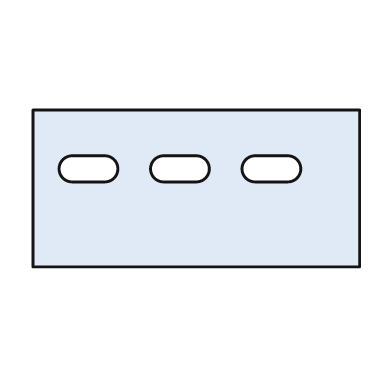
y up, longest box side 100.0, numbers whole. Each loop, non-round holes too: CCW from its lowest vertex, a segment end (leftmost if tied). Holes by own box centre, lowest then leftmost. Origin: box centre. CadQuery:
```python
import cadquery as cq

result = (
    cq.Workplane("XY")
    .moveTo(-50.0, -24.0)
    .lineTo(50.0, -24.0)
    .lineTo(50.0, 24.0)
    .lineTo(-50.0, 24.0)
    .close()
    .moveTo(-38.0, 2.0)
    .lineTo(-28.0, 2.0)
    .threePointArc((-24.0, 6.0), (-28.0, 10.0))
    .lineTo(-38.0, 10.0)
    .threePointArc((-42.0, 6.0), (-38.0, 2.0))
    .close()
    .moveTo(-10.0, 2.0)
    .lineTo(0.0, 2.0)
    .threePointArc((4.0, 6.0), (0.0, 10.0))
    .lineTo(-10.0, 10.0)
    .threePointArc((-14.0, 6.0), (-10.0, 2.0))
    .close()
    .moveTo(18.0, 2.0)
    .lineTo(28.0, 2.0)
    .threePointArc((32.0, 6.0), (28.0, 10.0))
    .lineTo(18.0, 10.0)
    .threePointArc((14.0, 6.0), (18.0, 2.0))
    .close()
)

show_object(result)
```